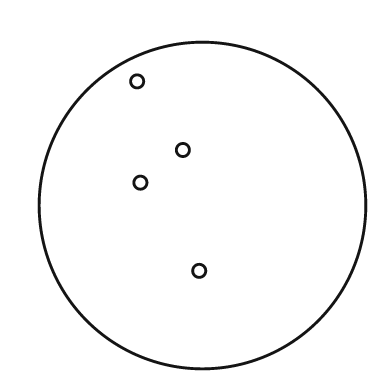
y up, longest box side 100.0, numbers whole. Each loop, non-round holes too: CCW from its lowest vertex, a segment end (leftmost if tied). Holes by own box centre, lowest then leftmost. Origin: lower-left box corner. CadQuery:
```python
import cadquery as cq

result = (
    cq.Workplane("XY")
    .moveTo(50.0, 50.0)
    .circle(50.0)
    .moveTo(49.0, 30.0)
    .circle(2.0)
    .moveTo(31.0, 57.0)
    .circle(2.0)
    .moveTo(44.0, 67.0)
    .circle(2.0)
    .moveTo(30.0, 88.0)
    .circle(2.0)
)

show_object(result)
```